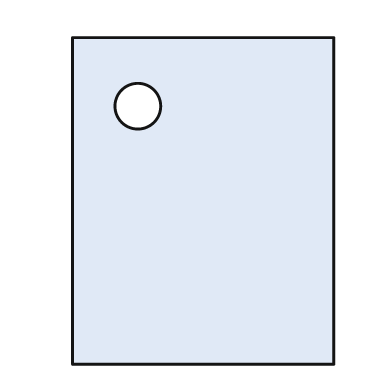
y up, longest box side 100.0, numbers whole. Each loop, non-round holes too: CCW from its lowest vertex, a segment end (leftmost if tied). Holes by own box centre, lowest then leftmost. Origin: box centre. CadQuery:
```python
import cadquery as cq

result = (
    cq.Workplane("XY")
    .moveTo(-40.0, -50.0)
    .lineTo(40.0, -50.0)
    .lineTo(40.0, 50.0)
    .lineTo(-40.0, 50.0)
    .close()
    .moveTo(-20.0, 29.0)
    .circle(7.0)
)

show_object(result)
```